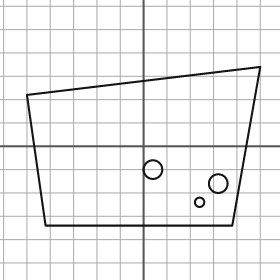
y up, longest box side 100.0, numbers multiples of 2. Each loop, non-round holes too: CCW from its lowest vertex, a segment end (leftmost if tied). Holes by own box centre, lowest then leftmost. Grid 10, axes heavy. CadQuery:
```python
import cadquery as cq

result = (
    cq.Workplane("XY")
    .moveTo(-42.0, -34.0)
    .lineTo(38.0, -34.0)
    .lineTo(50.0, 34.0)
    .lineTo(-50.0, 22.0)
    .close()
    .moveTo(24.0, -24.0)
    .circle(2.0)
    .moveTo(32.0, -16.0)
    .circle(4.0)
    .moveTo(4.0, -10.0)
    .circle(4.0)
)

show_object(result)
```